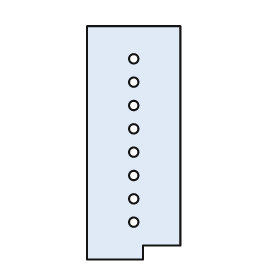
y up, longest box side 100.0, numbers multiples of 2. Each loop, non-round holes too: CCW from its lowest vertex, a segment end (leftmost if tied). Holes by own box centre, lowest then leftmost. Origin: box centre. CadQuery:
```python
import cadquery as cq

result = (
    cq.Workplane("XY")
    .moveTo(-20.0, -50.0)
    .lineTo(4.0, -50.0)
    .lineTo(4.0, -44.0)
    .lineTo(20.0, -44.0)
    .lineTo(20.0, 50.0)
    .lineTo(-20.0, 50.0)
    .close()
    .moveTo(0.0, -34.0)
    .circle(2.0)
    .moveTo(0.0, -24.0)
    .circle(2.0)
    .moveTo(0.0, -14.0)
    .circle(2.0)
    .moveTo(0.0, -4.0)
    .circle(2.0)
    .moveTo(0.0, 6.0)
    .circle(2.0)
    .moveTo(0.0, 16.0)
    .circle(2.0)
    .moveTo(0.0, 26.0)
    .circle(2.0)
    .moveTo(0.0, 36.0)
    .circle(2.0)
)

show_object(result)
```